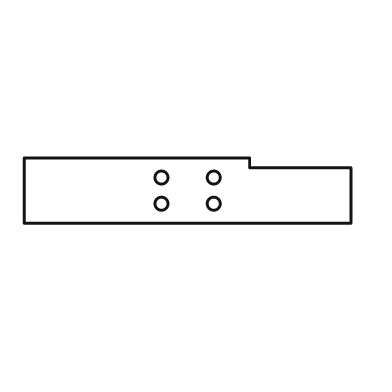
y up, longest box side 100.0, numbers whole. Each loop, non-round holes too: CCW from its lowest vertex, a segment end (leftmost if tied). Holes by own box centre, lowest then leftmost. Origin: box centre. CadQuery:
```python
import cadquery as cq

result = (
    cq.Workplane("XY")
    .moveTo(-50.0, -10.0)
    .lineTo(50.0, -10.0)
    .lineTo(50.0, 7.0)
    .lineTo(19.0, 7.0)
    .lineTo(19.0, 10.0)
    .lineTo(-50.0, 10.0)
    .close()
    .moveTo(-8.0, -4.0)
    .circle(2.0)
    .moveTo(8.0, -4.0)
    .circle(2.0)
    .moveTo(-8.0, 4.0)
    .circle(2.0)
    .moveTo(8.0, 4.0)
    .circle(2.0)
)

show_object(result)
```